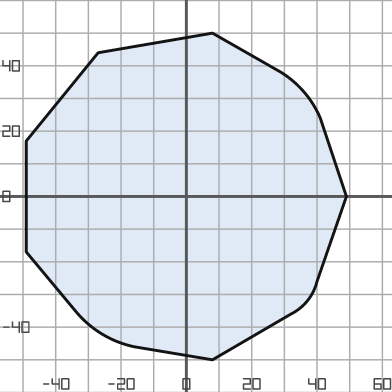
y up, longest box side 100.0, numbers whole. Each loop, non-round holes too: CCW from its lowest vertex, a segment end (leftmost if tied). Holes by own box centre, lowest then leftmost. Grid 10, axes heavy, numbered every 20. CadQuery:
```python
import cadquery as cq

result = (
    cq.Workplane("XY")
    .moveTo(8.0, -50.0)
    .lineTo(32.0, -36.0)
    .threePointArc((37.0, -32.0), (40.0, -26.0))
    .lineTo(49.0, 0.0)
    .lineTo(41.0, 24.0)
    .threePointArc((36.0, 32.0), (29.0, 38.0))
    .lineTo(8.0, 50.0)
    .lineTo(-27.0, 44.0)
    .lineTo(-49.0, 17.0)
    .lineTo(-49.0, -17.0)
    .lineTo(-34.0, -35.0)
    .threePointArc((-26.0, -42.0), (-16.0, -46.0))
    .close()
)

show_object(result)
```